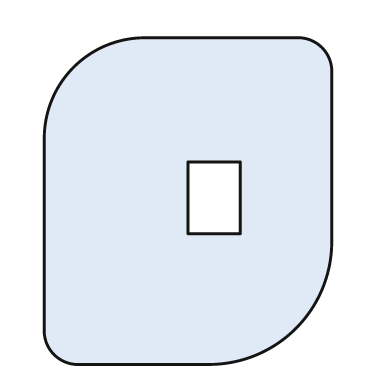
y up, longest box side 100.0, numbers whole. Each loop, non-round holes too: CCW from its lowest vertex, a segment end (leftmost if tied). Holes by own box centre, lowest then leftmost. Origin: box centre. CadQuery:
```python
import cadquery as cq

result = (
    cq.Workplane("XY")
    .moveTo(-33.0, -50.0)
    .lineTo(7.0, -50.0)
    .threePointArc((33.0, -39.0), (44.0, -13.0))
    .lineTo(44.0, 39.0)
    .threePointArc((41.0, 47.0), (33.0, 50.0))
    .lineTo(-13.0, 50.0)
    .threePointArc((-35.0, 41.0), (-44.0, 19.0))
    .lineTo(-44.0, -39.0)
    .threePointArc((-41.0, -47.0), (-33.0, -50.0))
    .close()
    .moveTo(0.0, -10.0)
    .lineTo(16.0, -10.0)
    .lineTo(16.0, 12.0)
    .lineTo(0.0, 12.0)
    .close()
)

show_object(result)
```